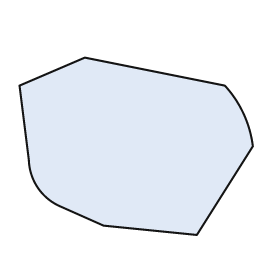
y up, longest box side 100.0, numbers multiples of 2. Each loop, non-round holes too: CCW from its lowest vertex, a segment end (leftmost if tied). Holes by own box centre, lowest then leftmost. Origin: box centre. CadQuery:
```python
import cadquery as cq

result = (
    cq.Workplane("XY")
    .moveTo(26.0, -38.0)
    .lineTo(50.0, 0.0)
    .threePointArc((46.0, 14.0), (38.0, 26.0))
    .lineTo(-22.0, 38.0)
    .lineTo(-50.0, 26.0)
    .lineTo(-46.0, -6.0)
    .threePointArc((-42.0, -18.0), (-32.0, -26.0))
    .lineTo(-14.0, -34.0)
    .close()
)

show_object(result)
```